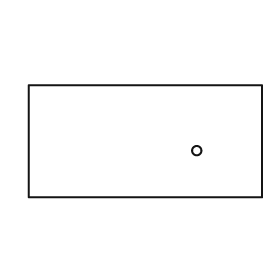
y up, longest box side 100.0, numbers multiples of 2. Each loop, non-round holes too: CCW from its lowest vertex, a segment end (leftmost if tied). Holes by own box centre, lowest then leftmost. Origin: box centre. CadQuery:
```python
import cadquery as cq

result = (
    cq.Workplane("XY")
    .moveTo(-50.0, -24.0)
    .lineTo(50.0, -24.0)
    .lineTo(50.0, 24.0)
    .lineTo(-50.0, 24.0)
    .close()
    .moveTo(22.0, -4.0)
    .circle(2.0)
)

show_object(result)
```